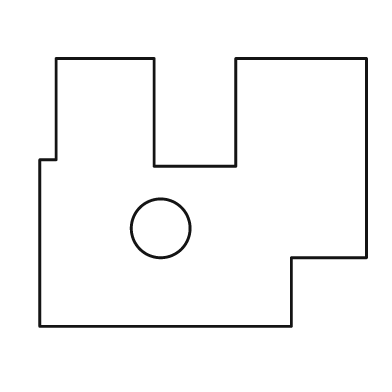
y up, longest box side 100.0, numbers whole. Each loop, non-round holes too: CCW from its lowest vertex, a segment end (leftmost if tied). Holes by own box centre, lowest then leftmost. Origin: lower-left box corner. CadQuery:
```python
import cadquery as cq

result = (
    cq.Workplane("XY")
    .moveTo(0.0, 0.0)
    .lineTo(77.0, 0.0)
    .lineTo(77.0, 21.0)
    .lineTo(100.0, 21.0)
    .lineTo(100.0, 82.0)
    .lineTo(60.0, 82.0)
    .lineTo(60.0, 49.0)
    .lineTo(35.0, 49.0)
    .lineTo(35.0, 82.0)
    .lineTo(5.0, 82.0)
    .lineTo(5.0, 51.0)
    .lineTo(0.0, 51.0)
    .close()
    .moveTo(37.0, 30.0)
    .circle(9.0)
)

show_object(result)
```